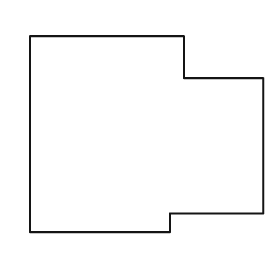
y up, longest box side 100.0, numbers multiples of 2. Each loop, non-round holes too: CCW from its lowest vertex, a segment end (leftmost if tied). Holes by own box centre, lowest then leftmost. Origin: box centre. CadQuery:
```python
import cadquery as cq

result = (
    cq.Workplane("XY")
    .moveTo(-50.0, -42.0)
    .lineTo(10.0, -42.0)
    .lineTo(10.0, -34.0)
    .lineTo(50.0, -34.0)
    .lineTo(50.0, 24.0)
    .lineTo(16.0, 24.0)
    .lineTo(16.0, 42.0)
    .lineTo(-50.0, 42.0)
    .close()
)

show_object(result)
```